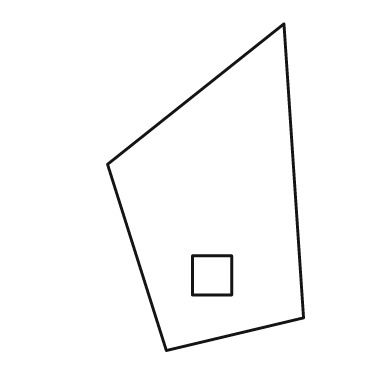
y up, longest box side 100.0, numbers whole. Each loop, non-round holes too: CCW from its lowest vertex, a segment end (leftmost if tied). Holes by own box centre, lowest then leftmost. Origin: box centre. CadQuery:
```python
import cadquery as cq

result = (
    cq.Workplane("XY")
    .moveTo(-12.0, -50.0)
    .lineTo(30.0, -40.0)
    .lineTo(24.0, 50.0)
    .lineTo(-30.0, 7.0)
    .close()
    .moveTo(-4.0, -33.0)
    .lineTo(8.0, -33.0)
    .lineTo(8.0, -21.0)
    .lineTo(-4.0, -21.0)
    .close()
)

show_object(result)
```